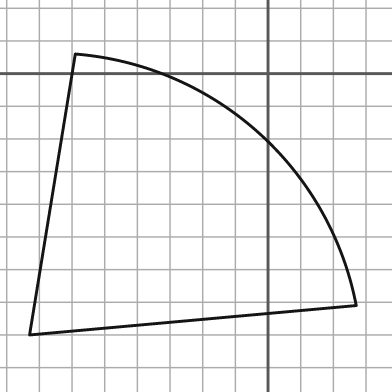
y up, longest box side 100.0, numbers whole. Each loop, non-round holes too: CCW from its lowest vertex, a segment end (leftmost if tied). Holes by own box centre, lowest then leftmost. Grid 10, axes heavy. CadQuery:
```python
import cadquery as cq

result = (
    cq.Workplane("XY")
    .moveTo(-73.0, -80.0)
    .lineTo(27.0, -71.0)
    .threePointArc((-3.0, -18.0), (-59.0, 6.0))
    .close()
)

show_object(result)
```